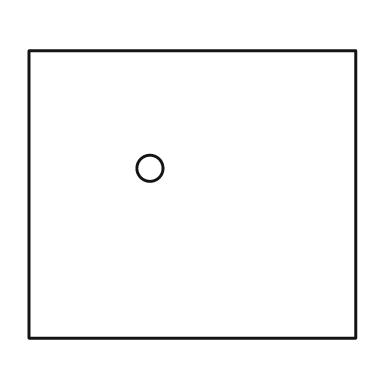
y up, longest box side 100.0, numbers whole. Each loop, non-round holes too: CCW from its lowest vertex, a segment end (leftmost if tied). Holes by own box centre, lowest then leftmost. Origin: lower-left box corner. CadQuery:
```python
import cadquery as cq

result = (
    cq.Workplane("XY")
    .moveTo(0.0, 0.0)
    .lineTo(100.0, 0.0)
    .lineTo(100.0, 88.0)
    .lineTo(0.0, 88.0)
    .close()
    .moveTo(37.0, 52.0)
    .circle(4.0)
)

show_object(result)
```